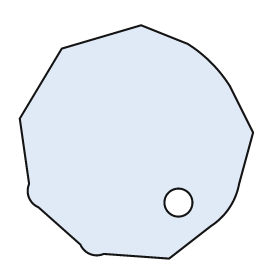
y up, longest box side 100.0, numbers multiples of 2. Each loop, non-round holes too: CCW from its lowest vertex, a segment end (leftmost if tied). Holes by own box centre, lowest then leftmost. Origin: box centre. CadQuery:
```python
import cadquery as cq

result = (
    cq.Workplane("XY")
    .moveTo(14.0, -50.0)
    .lineTo(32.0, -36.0)
    .threePointArc((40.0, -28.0), (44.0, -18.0))
    .lineTo(50.0, 4.0)
    .lineTo(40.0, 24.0)
    .threePointArc((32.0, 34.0), (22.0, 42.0))
    .lineTo(2.0, 50.0)
    .lineTo(-32.0, 40.0)
    .lineTo(-50.0, 10.0)
    .lineTo(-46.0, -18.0)
    .threePointArc((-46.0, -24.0), (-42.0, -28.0))
    .lineTo(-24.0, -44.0)
    .threePointArc((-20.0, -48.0), (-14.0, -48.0))
    .close()
    .moveTo(18.0, -26.0)
    .circle(6.0)
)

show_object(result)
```